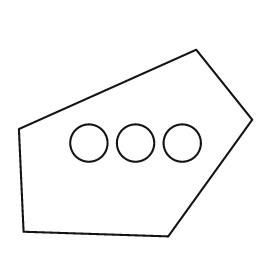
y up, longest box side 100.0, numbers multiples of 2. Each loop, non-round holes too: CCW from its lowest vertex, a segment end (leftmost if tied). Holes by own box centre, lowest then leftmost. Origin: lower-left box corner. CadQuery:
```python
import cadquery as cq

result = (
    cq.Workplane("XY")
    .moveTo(64.0, 0.0)
    .lineTo(100.0, 50.0)
    .lineTo(76.0, 80.0)
    .lineTo(0.0, 46.0)
    .lineTo(2.0, 2.0)
    .close()
    .moveTo(30.0, 40.0)
    .circle(8.0)
    .moveTo(50.0, 40.0)
    .circle(8.0)
    .moveTo(70.0, 40.0)
    .circle(8.0)
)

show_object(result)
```